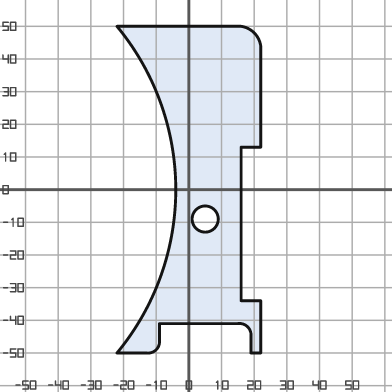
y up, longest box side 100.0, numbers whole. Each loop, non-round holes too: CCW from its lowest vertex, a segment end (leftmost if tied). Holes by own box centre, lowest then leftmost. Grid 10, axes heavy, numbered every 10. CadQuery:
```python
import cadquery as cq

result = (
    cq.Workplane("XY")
    .moveTo(-22.0, -50.0)
    .lineTo(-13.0, -50.0)
    .threePointArc((-10.0, -49.0), (-9.0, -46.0))
    .lineTo(-9.0, -41.0)
    .lineTo(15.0, -41.0)
    .threePointArc((18.0, -42.0), (19.0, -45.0))
    .lineTo(19.0, -50.0)
    .lineTo(22.0, -50.0)
    .lineTo(22.0, -34.0)
    .lineTo(16.0, -34.0)
    .lineTo(16.0, 13.0)
    .lineTo(22.0, 13.0)
    .lineTo(22.0, 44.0)
    .threePointArc((20.0, 48.0), (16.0, 50.0))
    .lineTo(-22.0, 50.0)
    .threePointArc((-4.0, 0.0), (-22.0, -50.0))
    .close()
    .moveTo(5.0, -9.0)
    .circle(4.0)
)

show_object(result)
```